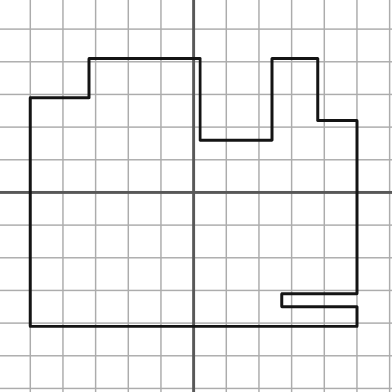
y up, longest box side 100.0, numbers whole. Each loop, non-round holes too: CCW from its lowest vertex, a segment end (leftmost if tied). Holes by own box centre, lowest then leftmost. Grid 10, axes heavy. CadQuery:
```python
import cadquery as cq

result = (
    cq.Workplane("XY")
    .moveTo(-50.0, -41.0)
    .lineTo(50.0, -41.0)
    .lineTo(50.0, -35.0)
    .lineTo(27.0, -35.0)
    .lineTo(27.0, -31.0)
    .lineTo(50.0, -31.0)
    .lineTo(50.0, 22.0)
    .lineTo(38.0, 22.0)
    .lineTo(38.0, 41.0)
    .lineTo(24.0, 41.0)
    .lineTo(24.0, 16.0)
    .lineTo(2.0, 16.0)
    .lineTo(2.0, 41.0)
    .lineTo(-32.0, 41.0)
    .lineTo(-32.0, 29.0)
    .lineTo(-50.0, 29.0)
    .close()
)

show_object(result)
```